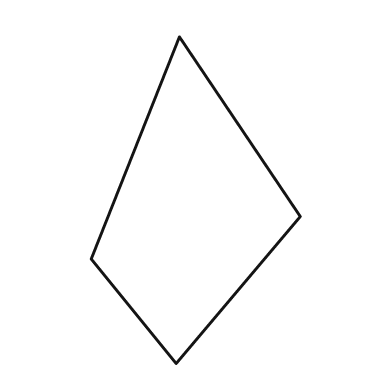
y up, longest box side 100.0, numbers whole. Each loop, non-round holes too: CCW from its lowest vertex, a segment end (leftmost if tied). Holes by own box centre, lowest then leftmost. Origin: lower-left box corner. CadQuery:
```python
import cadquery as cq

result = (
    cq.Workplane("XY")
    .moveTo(26.0, 0.0)
    .lineTo(64.0, 45.0)
    .lineTo(27.0, 100.0)
    .lineTo(0.0, 32.0)
    .close()
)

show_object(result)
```